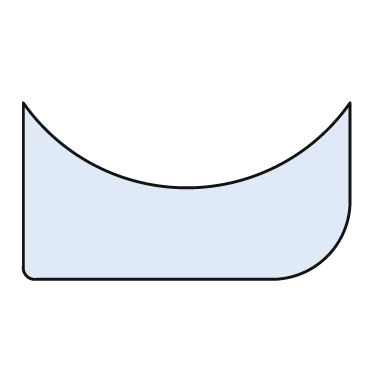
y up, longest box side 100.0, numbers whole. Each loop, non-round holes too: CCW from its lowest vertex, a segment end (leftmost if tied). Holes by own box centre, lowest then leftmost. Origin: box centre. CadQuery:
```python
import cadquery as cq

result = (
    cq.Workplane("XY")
    .moveTo(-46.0, -27.0)
    .lineTo(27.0, -27.0)
    .threePointArc((43.0, -20.0), (50.0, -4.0))
    .lineTo(50.0, 27.0)
    .threePointArc((0.0, 1.0), (-50.0, 27.0))
    .lineTo(-50.0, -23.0)
    .threePointArc((-49.0, -26.0), (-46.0, -27.0))
    .close()
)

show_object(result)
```